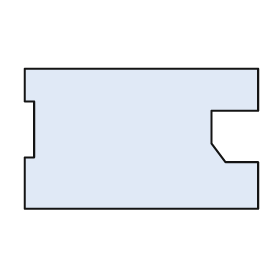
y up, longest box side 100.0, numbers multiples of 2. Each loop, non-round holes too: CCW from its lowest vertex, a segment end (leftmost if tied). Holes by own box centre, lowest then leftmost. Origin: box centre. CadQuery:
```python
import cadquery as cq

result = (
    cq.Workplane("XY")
    .moveTo(-50.0, -30.0)
    .lineTo(50.0, -30.0)
    .lineTo(50.0, -10.0)
    .lineTo(36.0, -10.0)
    .lineTo(30.0, -2.0)
    .lineTo(30.0, 12.0)
    .lineTo(50.0, 12.0)
    .lineTo(50.0, 30.0)
    .lineTo(-50.0, 30.0)
    .lineTo(-50.0, 16.0)
    .lineTo(-46.0, 16.0)
    .lineTo(-46.0, -8.0)
    .lineTo(-50.0, -8.0)
    .close()
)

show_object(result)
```